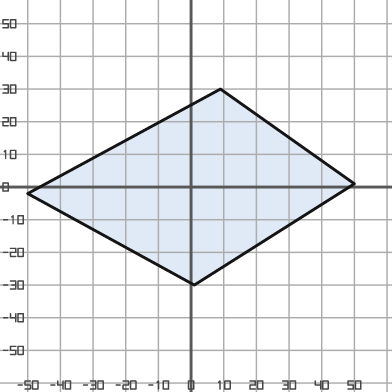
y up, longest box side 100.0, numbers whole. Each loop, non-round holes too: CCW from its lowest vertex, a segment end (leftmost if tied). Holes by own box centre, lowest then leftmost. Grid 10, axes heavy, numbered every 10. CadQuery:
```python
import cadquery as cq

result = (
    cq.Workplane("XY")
    .moveTo(1.0, -30.0)
    .lineTo(50.0, 1.0)
    .lineTo(9.0, 30.0)
    .lineTo(-50.0, -2.0)
    .close()
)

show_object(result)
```